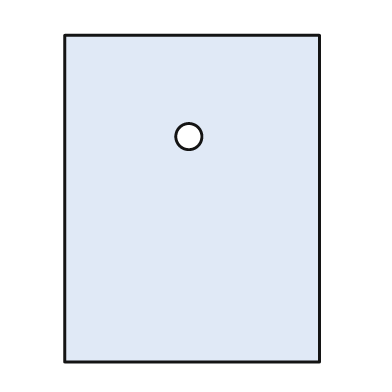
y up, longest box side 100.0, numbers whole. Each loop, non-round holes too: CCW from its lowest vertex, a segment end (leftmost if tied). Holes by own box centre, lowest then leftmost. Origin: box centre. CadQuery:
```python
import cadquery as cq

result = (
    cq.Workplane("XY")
    .moveTo(-39.0, -50.0)
    .lineTo(39.0, -50.0)
    .lineTo(39.0, 50.0)
    .lineTo(-39.0, 50.0)
    .close()
    .moveTo(-1.0, 19.0)
    .circle(4.0)
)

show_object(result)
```